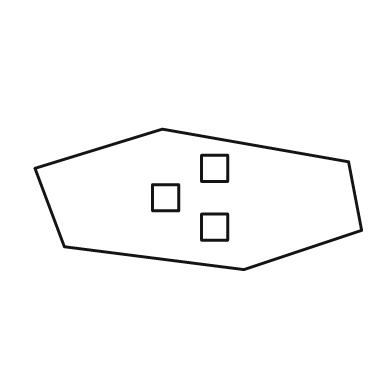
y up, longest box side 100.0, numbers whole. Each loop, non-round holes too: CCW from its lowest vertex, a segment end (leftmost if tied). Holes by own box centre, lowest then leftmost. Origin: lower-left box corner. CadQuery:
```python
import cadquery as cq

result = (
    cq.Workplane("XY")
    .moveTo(64.0, 0.0)
    .lineTo(100.0, 12.0)
    .lineTo(96.0, 33.0)
    .lineTo(39.0, 43.0)
    .lineTo(0.0, 31.0)
    .lineTo(9.0, 7.0)
    .close()
    .moveTo(51.0, 9.0)
    .lineTo(59.0, 9.0)
    .lineTo(59.0, 17.0)
    .lineTo(51.0, 17.0)
    .close()
    .moveTo(36.0, 18.0)
    .lineTo(44.0, 18.0)
    .lineTo(44.0, 26.0)
    .lineTo(36.0, 26.0)
    .close()
    .moveTo(51.0, 27.0)
    .lineTo(59.0, 27.0)
    .lineTo(59.0, 35.0)
    .lineTo(51.0, 35.0)
    .close()
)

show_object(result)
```